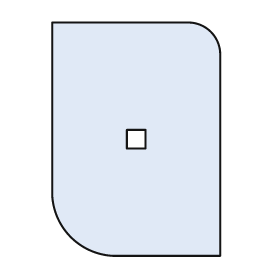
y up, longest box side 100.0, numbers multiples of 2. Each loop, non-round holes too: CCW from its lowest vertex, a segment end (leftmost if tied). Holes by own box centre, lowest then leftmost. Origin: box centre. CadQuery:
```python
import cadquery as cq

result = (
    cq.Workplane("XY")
    .moveTo(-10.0, -50.0)
    .lineTo(36.0, -50.0)
    .lineTo(36.0, 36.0)
    .threePointArc((32.0, 46.0), (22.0, 50.0))
    .lineTo(-36.0, 50.0)
    .lineTo(-36.0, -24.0)
    .threePointArc((-28.0, -42.0), (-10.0, -50.0))
    .close()
    .moveTo(-4.0, -4.0)
    .lineTo(4.0, -4.0)
    .lineTo(4.0, 4.0)
    .lineTo(-4.0, 4.0)
    .close()
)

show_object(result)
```